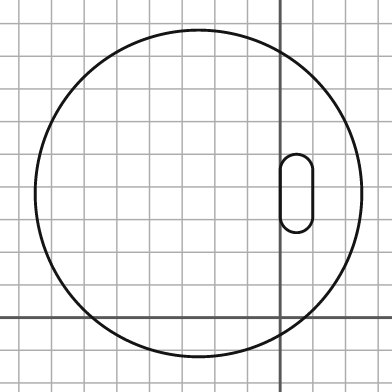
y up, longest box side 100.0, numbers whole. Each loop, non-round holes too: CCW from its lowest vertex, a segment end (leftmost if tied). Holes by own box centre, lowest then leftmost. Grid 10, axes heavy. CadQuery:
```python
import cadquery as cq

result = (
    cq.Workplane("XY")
    .moveTo(-25.0, 38.0)
    .circle(50.0)
    .moveTo(0.0, 31.0)
    .threePointArc((5.0, 26.0), (10.0, 31.0))
    .lineTo(10.0, 45.0)
    .threePointArc((5.0, 50.0), (0.0, 45.0))
    .close()
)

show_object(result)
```